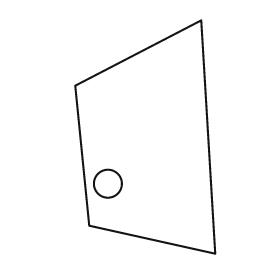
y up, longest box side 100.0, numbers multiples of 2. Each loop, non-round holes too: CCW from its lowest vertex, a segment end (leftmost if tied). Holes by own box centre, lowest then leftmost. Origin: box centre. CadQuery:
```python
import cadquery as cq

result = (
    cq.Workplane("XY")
    .moveTo(30.0, -50.0)
    .lineTo(24.0, 50.0)
    .lineTo(-30.0, 22.0)
    .lineTo(-24.0, -38.0)
    .close()
    .moveTo(-16.0, -20.0)
    .circle(6.0)
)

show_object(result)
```